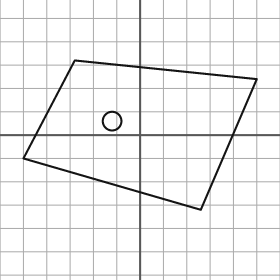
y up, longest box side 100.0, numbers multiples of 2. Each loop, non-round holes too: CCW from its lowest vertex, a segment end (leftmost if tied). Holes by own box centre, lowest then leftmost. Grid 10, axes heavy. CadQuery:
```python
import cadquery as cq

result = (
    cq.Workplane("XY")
    .moveTo(26.0, -32.0)
    .lineTo(50.0, 24.0)
    .lineTo(-28.0, 32.0)
    .lineTo(-50.0, -10.0)
    .close()
    .moveTo(-12.0, 6.0)
    .circle(4.0)
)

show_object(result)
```